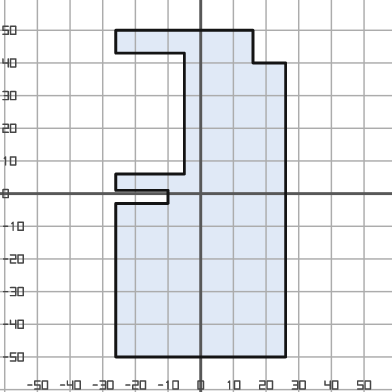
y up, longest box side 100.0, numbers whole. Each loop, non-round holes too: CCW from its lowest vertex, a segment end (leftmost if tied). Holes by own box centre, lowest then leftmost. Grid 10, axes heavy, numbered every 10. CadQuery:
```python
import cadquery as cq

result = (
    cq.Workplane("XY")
    .moveTo(-26.0, -50.0)
    .lineTo(26.0, -50.0)
    .lineTo(26.0, 40.0)
    .lineTo(16.0, 40.0)
    .lineTo(16.0, 50.0)
    .lineTo(-26.0, 50.0)
    .lineTo(-26.0, 43.0)
    .lineTo(-5.0, 43.0)
    .lineTo(-5.0, 6.0)
    .lineTo(-26.0, 6.0)
    .lineTo(-26.0, 1.0)
    .lineTo(-10.0, 1.0)
    .lineTo(-10.0, -3.0)
    .lineTo(-26.0, -3.0)
    .close()
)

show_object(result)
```